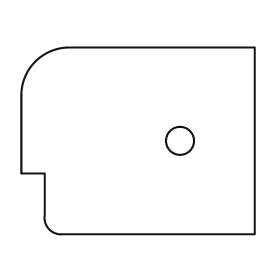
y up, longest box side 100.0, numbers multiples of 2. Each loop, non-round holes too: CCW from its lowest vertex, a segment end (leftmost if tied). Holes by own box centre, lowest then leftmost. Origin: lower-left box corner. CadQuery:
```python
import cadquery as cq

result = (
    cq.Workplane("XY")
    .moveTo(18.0, 0.0)
    .lineTo(100.0, 0.0)
    .lineTo(100.0, 80.0)
    .lineTo(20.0, 80.0)
    .threePointArc((6.0, 74.0), (0.0, 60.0))
    .lineTo(0.0, 26.0)
    .lineTo(10.0, 26.0)
    .lineTo(10.0, 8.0)
    .threePointArc((12.0, 2.0), (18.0, 0.0))
    .close()
    .moveTo(68.0, 40.0)
    .circle(6.0)
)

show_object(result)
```